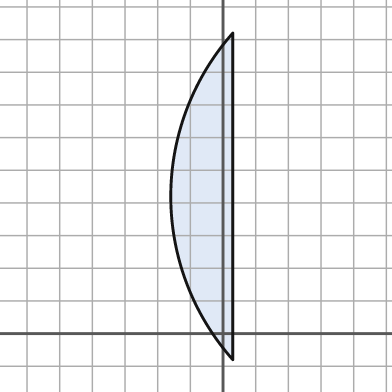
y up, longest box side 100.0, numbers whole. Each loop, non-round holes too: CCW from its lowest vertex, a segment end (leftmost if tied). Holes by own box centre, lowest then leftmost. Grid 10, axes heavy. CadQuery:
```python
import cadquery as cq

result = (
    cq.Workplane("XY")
    .moveTo(3.0, -8.0)
    .lineTo(3.0, 92.0)
    .threePointArc((-16.0, 42.0), (3.0, -8.0))
    .close()
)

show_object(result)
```